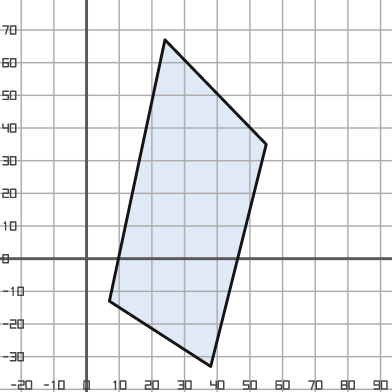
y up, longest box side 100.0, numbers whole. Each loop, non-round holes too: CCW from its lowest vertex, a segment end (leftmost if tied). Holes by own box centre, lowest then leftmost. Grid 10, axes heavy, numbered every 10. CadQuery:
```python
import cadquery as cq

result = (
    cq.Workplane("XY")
    .moveTo(38.0, -33.0)
    .lineTo(55.0, 35.0)
    .lineTo(24.0, 67.0)
    .lineTo(7.0, -13.0)
    .close()
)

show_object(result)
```